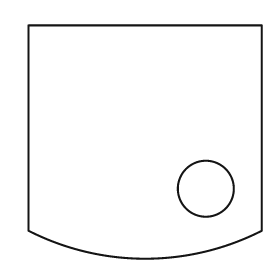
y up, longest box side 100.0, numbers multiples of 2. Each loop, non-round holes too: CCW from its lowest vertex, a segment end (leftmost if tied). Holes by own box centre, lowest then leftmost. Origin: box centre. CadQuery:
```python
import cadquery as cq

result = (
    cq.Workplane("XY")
    .moveTo(-50.0, -38.0)
    .threePointArc((0.0, -50.0), (50.0, -38.0))
    .lineTo(50.0, 50.0)
    .lineTo(-50.0, 50.0)
    .close()
    .moveTo(26.0, -20.0)
    .circle(12.0)
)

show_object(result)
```